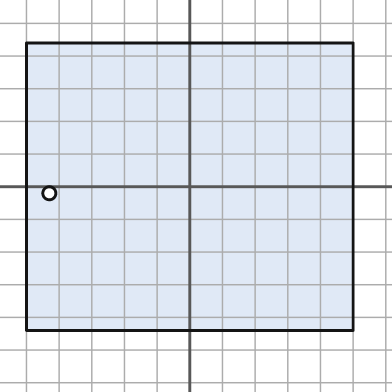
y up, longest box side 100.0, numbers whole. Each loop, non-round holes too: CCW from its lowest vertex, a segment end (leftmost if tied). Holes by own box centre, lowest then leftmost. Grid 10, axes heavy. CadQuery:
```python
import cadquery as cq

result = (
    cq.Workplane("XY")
    .moveTo(-50.0, -44.0)
    .lineTo(50.0, -44.0)
    .lineTo(50.0, 44.0)
    .lineTo(-50.0, 44.0)
    .close()
    .moveTo(-43.0, -2.0)
    .circle(2.0)
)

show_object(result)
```